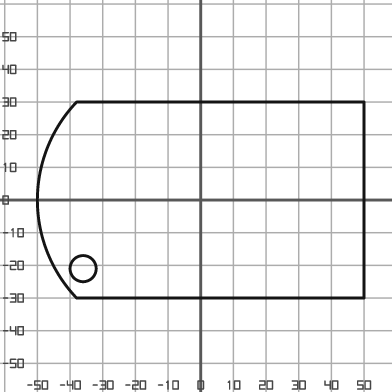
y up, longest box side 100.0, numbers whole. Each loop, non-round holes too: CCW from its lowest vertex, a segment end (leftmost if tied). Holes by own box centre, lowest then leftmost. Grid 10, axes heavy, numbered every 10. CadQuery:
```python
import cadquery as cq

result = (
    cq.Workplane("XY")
    .moveTo(-38.0, -30.0)
    .lineTo(50.0, -30.0)
    .lineTo(50.0, 30.0)
    .lineTo(-38.0, 30.0)
    .threePointArc((-50.0, 0.0), (-38.0, -30.0))
    .close()
    .moveTo(-36.0, -21.0)
    .circle(4.0)
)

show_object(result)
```